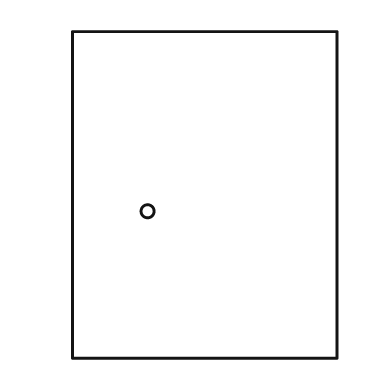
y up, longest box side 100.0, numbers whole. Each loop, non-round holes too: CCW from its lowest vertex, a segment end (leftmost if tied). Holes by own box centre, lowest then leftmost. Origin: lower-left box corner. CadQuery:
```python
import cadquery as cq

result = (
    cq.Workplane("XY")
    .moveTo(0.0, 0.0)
    .lineTo(81.0, 0.0)
    .lineTo(81.0, 100.0)
    .lineTo(0.0, 100.0)
    .close()
    .moveTo(23.0, 45.0)
    .circle(2.0)
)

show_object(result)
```